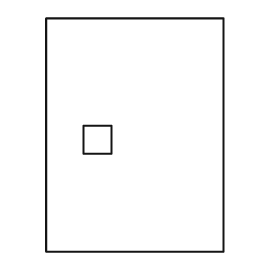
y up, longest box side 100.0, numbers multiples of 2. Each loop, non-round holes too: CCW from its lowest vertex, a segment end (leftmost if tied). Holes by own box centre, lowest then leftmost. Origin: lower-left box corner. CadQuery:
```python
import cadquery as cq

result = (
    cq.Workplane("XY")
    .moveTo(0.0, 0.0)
    .lineTo(76.0, 0.0)
    .lineTo(76.0, 100.0)
    .lineTo(0.0, 100.0)
    .close()
    .moveTo(16.0, 42.0)
    .lineTo(28.0, 42.0)
    .lineTo(28.0, 54.0)
    .lineTo(16.0, 54.0)
    .close()
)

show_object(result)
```